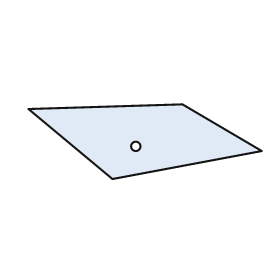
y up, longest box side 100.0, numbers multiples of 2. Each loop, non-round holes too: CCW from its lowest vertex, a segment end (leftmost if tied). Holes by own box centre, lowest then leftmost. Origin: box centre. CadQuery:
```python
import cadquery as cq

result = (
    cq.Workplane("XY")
    .moveTo(-14.0, -16.0)
    .lineTo(50.0, -4.0)
    .lineTo(16.0, 16.0)
    .lineTo(-50.0, 14.0)
    .close()
    .moveTo(-4.0, -2.0)
    .circle(2.0)
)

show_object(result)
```